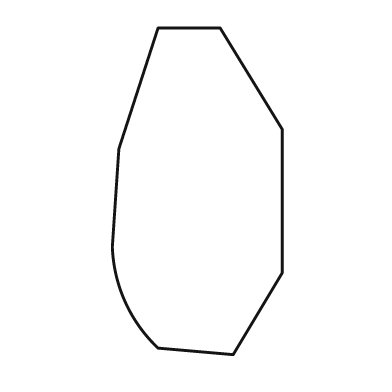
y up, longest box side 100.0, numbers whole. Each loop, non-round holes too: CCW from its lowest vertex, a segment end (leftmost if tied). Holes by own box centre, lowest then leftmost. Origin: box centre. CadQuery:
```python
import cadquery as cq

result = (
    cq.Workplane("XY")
    .moveTo(11.0, -50.0)
    .lineTo(26.0, -25.0)
    .lineTo(26.0, 19.0)
    .lineTo(7.0, 50.0)
    .lineTo(-12.0, 50.0)
    .lineTo(-24.0, 13.0)
    .lineTo(-26.0, -17.0)
    .threePointArc((-22.0, -34.0), (-12.0, -48.0))
    .close()
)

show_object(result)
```